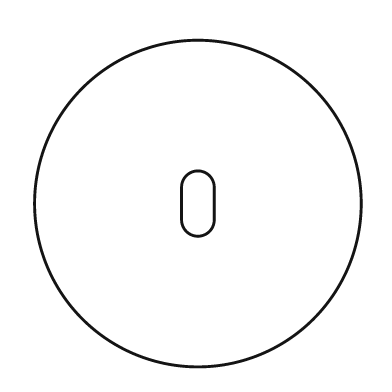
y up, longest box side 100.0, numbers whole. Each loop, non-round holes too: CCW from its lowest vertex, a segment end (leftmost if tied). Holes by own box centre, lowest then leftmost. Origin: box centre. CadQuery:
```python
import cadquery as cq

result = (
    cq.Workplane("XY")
    .moveTo(0.0, 0.0)
    .circle(50.0)
    .moveTo(-5.0, -5.0)
    .threePointArc((0.0, -10.0), (5.0, -5.0))
    .lineTo(5.0, 5.0)
    .threePointArc((0.0, 10.0), (-5.0, 5.0))
    .close()
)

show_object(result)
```